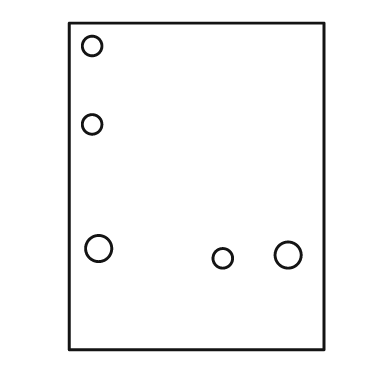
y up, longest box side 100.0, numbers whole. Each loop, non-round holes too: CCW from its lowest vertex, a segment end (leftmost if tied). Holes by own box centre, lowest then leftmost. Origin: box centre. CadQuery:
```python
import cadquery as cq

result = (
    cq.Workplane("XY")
    .moveTo(-39.0, -50.0)
    .lineTo(39.0, -50.0)
    .lineTo(39.0, 50.0)
    .lineTo(-39.0, 50.0)
    .close()
    .moveTo(8.0, -22.0)
    .circle(3.0)
    .moveTo(28.0, -21.0)
    .circle(4.0)
    .moveTo(-30.0, -19.0)
    .circle(4.0)
    .moveTo(-32.0, 19.0)
    .circle(3.0)
    .moveTo(-32.0, 43.0)
    .circle(3.0)
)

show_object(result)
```